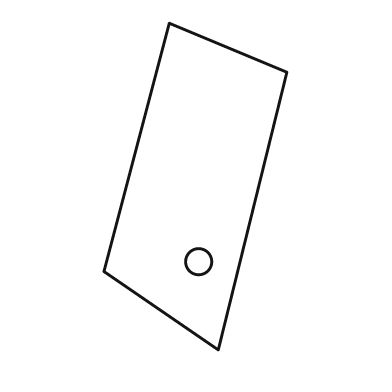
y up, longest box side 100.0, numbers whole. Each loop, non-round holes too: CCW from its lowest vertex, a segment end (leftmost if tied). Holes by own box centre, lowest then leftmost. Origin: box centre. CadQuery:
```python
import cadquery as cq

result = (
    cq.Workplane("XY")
    .moveTo(7.0, -50.0)
    .lineTo(28.0, 35.0)
    .lineTo(-8.0, 50.0)
    .lineTo(-28.0, -26.0)
    .close()
    .moveTo(1.0, -23.0)
    .circle(4.0)
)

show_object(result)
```